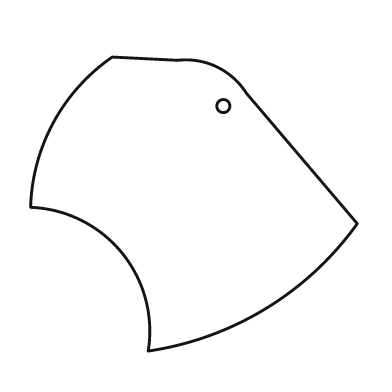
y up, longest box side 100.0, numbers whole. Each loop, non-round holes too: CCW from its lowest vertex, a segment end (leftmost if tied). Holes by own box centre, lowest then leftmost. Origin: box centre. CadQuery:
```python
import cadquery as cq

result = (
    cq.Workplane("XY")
    .moveTo(-14.0, -45.0)
    .threePointArc((22.0, -32.0), (50.0, -6.0))
    .lineTo(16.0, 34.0)
    .threePointArc((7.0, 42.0), (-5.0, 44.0))
    .lineTo(-25.0, 45.0)
    .threePointArc((-43.0, 25.0), (-50.0, -1.0))
    .threePointArc((-22.0, -15.0), (-14.0, -45.0))
    .close()
    .moveTo(9.0, 30.0)
    .circle(2.0)
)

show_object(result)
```